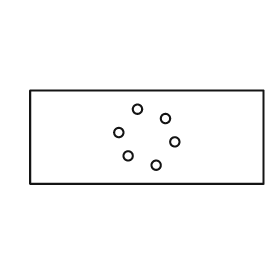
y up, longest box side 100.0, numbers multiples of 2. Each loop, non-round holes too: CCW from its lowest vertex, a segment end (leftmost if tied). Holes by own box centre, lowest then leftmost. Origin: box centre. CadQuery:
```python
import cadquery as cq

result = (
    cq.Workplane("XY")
    .moveTo(-50.0, -20.0)
    .lineTo(50.0, -20.0)
    .lineTo(50.0, 20.0)
    .lineTo(-50.0, 20.0)
    .close()
    .moveTo(4.0, -12.0)
    .circle(2.0)
    .moveTo(-8.0, -8.0)
    .circle(2.0)
    .moveTo(12.0, -2.0)
    .circle(2.0)
    .moveTo(-12.0, 2.0)
    .circle(2.0)
    .moveTo(8.0, 8.0)
    .circle(2.0)
    .moveTo(-4.0, 12.0)
    .circle(2.0)
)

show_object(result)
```